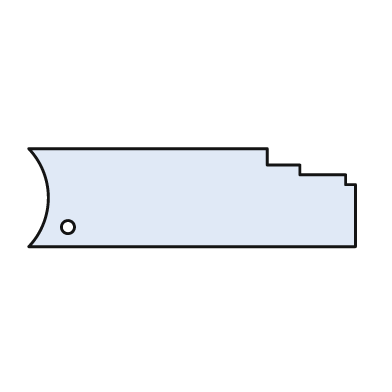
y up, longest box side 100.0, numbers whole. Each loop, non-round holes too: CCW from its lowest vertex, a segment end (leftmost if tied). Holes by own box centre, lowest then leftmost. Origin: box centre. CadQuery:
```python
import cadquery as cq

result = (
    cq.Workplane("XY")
    .moveTo(-50.0, -15.0)
    .lineTo(50.0, -15.0)
    .lineTo(50.0, 4.0)
    .lineTo(47.0, 4.0)
    .lineTo(47.0, 7.0)
    .lineTo(33.0, 7.0)
    .lineTo(33.0, 10.0)
    .lineTo(23.0, 10.0)
    .lineTo(23.0, 15.0)
    .lineTo(-50.0, 15.0)
    .threePointArc((-44.0, 0.0), (-50.0, -15.0))
    .close()
    .moveTo(-38.0, -9.0)
    .circle(2.0)
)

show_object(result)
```